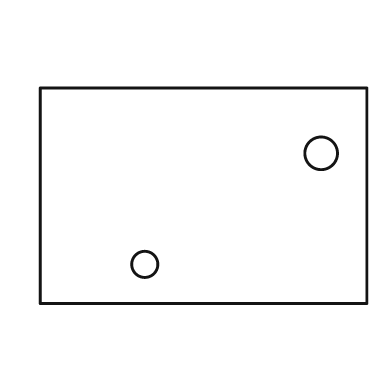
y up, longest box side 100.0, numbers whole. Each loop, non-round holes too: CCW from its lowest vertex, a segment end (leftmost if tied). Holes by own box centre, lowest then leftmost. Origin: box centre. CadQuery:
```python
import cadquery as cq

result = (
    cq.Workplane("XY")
    .moveTo(-50.0, -33.0)
    .lineTo(50.0, -33.0)
    .lineTo(50.0, 33.0)
    .lineTo(-50.0, 33.0)
    .close()
    .moveTo(-18.0, -21.0)
    .circle(4.0)
    .moveTo(36.0, 13.0)
    .circle(5.0)
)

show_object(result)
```